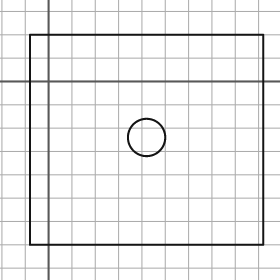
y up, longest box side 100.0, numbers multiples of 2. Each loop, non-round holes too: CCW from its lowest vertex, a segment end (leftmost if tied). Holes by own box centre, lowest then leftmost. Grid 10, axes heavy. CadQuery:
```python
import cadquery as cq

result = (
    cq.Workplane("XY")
    .moveTo(-8.0, -70.0)
    .lineTo(92.0, -70.0)
    .lineTo(92.0, 20.0)
    .lineTo(-8.0, 20.0)
    .close()
    .moveTo(42.0, -24.0)
    .circle(8.0)
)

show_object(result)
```